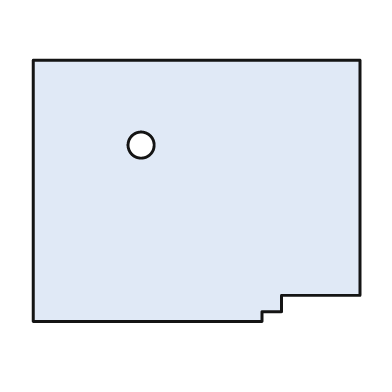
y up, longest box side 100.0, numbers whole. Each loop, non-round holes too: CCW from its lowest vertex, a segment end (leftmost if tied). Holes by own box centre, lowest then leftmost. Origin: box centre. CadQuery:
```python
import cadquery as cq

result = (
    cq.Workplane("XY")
    .moveTo(-50.0, -40.0)
    .lineTo(20.0, -40.0)
    .lineTo(20.0, -37.0)
    .lineTo(26.0, -37.0)
    .lineTo(26.0, -32.0)
    .lineTo(50.0, -32.0)
    .lineTo(50.0, 40.0)
    .lineTo(-50.0, 40.0)
    .close()
    .moveTo(-17.0, 14.0)
    .circle(4.0)
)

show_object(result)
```